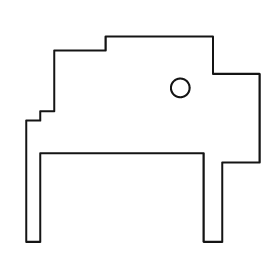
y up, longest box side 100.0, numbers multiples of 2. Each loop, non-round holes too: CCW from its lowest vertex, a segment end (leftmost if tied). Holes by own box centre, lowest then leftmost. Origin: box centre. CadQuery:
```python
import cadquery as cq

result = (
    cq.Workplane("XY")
    .moveTo(-50.0, -44.0)
    .lineTo(-44.0, -44.0)
    .lineTo(-44.0, -6.0)
    .lineTo(26.0, -6.0)
    .lineTo(26.0, -44.0)
    .lineTo(34.0, -44.0)
    .lineTo(34.0, -10.0)
    .lineTo(50.0, -10.0)
    .lineTo(50.0, 28.0)
    .lineTo(30.0, 28.0)
    .lineTo(30.0, 44.0)
    .lineTo(-16.0, 44.0)
    .lineTo(-16.0, 38.0)
    .lineTo(-38.0, 38.0)
    .lineTo(-38.0, 12.0)
    .lineTo(-44.0, 12.0)
    .lineTo(-44.0, 8.0)
    .lineTo(-50.0, 8.0)
    .close()
    .moveTo(16.0, 22.0)
    .circle(4.0)
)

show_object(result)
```